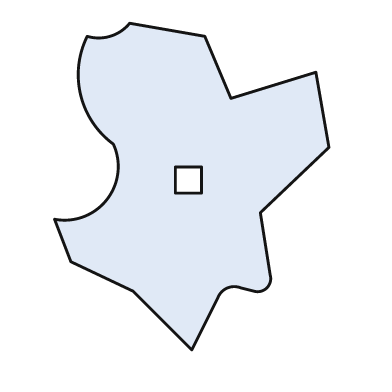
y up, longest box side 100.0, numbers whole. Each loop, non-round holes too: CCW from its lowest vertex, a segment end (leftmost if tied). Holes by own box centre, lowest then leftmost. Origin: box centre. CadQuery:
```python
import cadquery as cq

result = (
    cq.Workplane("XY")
    .moveTo(0.0, -50.0)
    .lineTo(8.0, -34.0)
    .threePointArc((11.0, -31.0), (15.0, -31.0))
    .lineTo(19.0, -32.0)
    .threePointArc((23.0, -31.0), (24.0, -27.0))
    .lineTo(21.0, -8.0)
    .lineTo(42.0, 12.0)
    .lineTo(38.0, 35.0)
    .lineTo(12.0, 27.0)
    .lineTo(4.0, 46.0)
    .lineTo(-19.0, 50.0)
    .threePointArc((-25.0, 46.0), (-32.0, 46.0))
    .threePointArc((-34.0, 28.0), (-24.0, 13.0))
    .threePointArc((-26.0, -4.0), (-42.0, -10.0))
    .lineTo(-37.0, -23.0)
    .lineTo(-18.0, -32.0)
    .close()
    .moveTo(-5.0, -2.0)
    .lineTo(3.0, -2.0)
    .lineTo(3.0, 6.0)
    .lineTo(-5.0, 6.0)
    .close()
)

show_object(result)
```